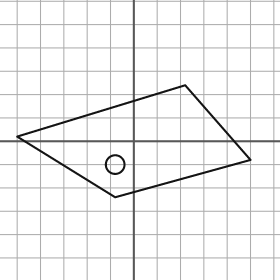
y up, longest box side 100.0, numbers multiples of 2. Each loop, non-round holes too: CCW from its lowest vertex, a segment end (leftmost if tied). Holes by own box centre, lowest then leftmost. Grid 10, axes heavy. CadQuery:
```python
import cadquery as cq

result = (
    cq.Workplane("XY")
    .moveTo(-8.0, -24.0)
    .lineTo(50.0, -8.0)
    .lineTo(22.0, 24.0)
    .lineTo(-50.0, 2.0)
    .close()
    .moveTo(-8.0, -10.0)
    .circle(4.0)
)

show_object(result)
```